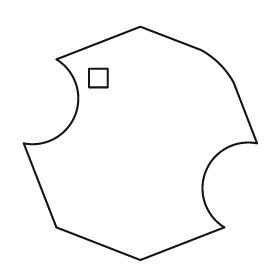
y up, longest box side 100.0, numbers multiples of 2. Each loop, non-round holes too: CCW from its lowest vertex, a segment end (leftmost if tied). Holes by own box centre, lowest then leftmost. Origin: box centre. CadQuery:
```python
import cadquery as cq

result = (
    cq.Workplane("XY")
    .moveTo(0.0, -50.0)
    .lineTo(36.0, -36.0)
    .threePointArc((28.0, -12.0), (50.0, 0.0))
    .lineTo(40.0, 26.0)
    .threePointArc((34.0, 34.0), (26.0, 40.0))
    .lineTo(0.0, 50.0)
    .lineTo(-36.0, 36.0)
    .threePointArc((-28.0, 12.0), (-50.0, 0.0))
    .lineTo(-36.0, -36.0)
    .close()
    .moveTo(-22.0, 24.0)
    .lineTo(-14.0, 24.0)
    .lineTo(-14.0, 32.0)
    .lineTo(-22.0, 32.0)
    .close()
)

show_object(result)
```